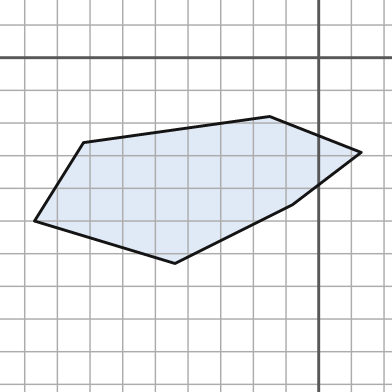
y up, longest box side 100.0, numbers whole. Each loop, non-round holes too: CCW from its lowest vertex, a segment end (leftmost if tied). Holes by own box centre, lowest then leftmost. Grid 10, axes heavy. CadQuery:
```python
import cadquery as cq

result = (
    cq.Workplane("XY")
    .moveTo(-44.0, -63.0)
    .lineTo(-8.0, -45.0)
    .lineTo(13.0, -29.0)
    .lineTo(-15.0, -18.0)
    .lineTo(-72.0, -26.0)
    .lineTo(-87.0, -50.0)
    .close()
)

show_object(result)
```